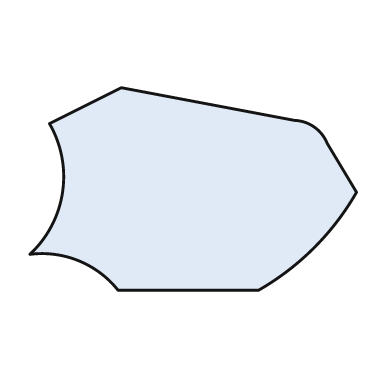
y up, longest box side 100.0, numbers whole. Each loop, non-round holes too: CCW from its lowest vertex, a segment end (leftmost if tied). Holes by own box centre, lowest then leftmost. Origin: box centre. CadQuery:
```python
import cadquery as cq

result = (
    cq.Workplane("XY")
    .moveTo(-23.0, -31.0)
    .lineTo(20.0, -31.0)
    .threePointArc((37.0, -18.0), (50.0, -1.0))
    .lineTo(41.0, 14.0)
    .threePointArc((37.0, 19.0), (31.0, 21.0))
    .lineTo(-22.0, 31.0)
    .lineTo(-44.0, 20.0)
    .threePointArc((-40.0, -1.0), (-50.0, -20.0))
    .threePointArc((-35.0, -22.0), (-23.0, -31.0))
    .close()
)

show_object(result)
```